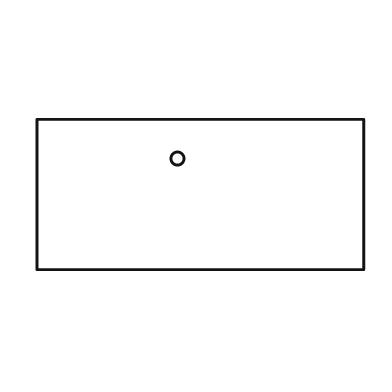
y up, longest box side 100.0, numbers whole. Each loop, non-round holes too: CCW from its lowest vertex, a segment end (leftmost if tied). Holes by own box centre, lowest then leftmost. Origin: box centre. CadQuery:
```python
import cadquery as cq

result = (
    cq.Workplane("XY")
    .moveTo(-50.0, -23.0)
    .lineTo(50.0, -23.0)
    .lineTo(50.0, 23.0)
    .lineTo(-50.0, 23.0)
    .close()
    .moveTo(-7.0, 11.0)
    .circle(2.0)
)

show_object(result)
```